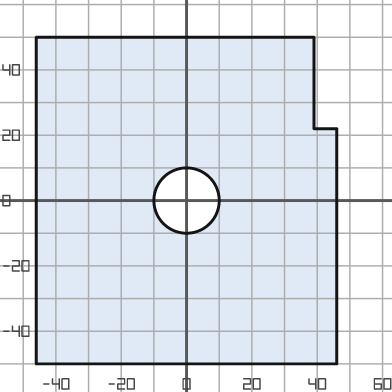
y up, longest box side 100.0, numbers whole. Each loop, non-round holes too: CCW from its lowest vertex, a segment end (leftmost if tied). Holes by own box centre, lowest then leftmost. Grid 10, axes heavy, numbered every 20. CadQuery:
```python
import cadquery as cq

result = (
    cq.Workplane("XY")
    .moveTo(-46.0, -50.0)
    .lineTo(46.0, -50.0)
    .lineTo(46.0, 22.0)
    .lineTo(39.0, 22.0)
    .lineTo(39.0, 50.0)
    .lineTo(-46.0, 50.0)
    .close()
    .moveTo(0.0, 0.0)
    .circle(10.0)
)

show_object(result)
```